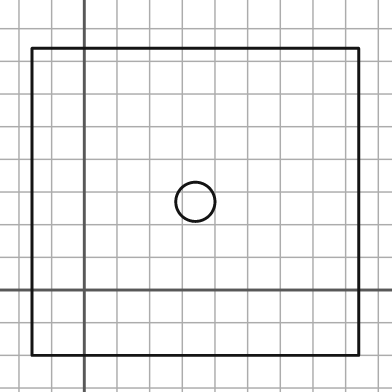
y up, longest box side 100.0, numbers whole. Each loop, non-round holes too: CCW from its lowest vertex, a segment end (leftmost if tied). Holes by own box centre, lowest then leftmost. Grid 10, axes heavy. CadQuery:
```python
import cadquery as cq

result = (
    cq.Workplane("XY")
    .moveTo(-16.0, -20.0)
    .lineTo(84.0, -20.0)
    .lineTo(84.0, 74.0)
    .lineTo(-16.0, 74.0)
    .close()
    .moveTo(34.0, 27.0)
    .circle(6.0)
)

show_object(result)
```